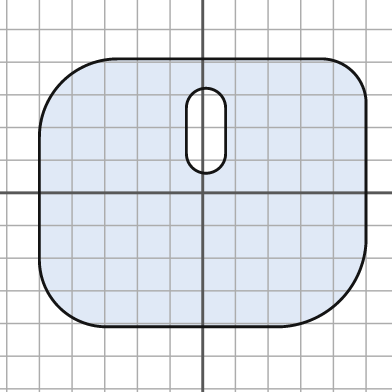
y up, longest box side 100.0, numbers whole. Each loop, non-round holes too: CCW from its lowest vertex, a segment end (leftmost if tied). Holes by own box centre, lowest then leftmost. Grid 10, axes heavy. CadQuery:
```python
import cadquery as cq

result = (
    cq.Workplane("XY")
    .moveTo(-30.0, -41.0)
    .lineTo(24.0, -41.0)
    .threePointArc((42.0, -33.0), (50.0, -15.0))
    .lineTo(50.0, 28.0)
    .threePointArc((46.0, 37.0), (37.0, 41.0))
    .lineTo(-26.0, 41.0)
    .threePointArc((-43.0, 34.0), (-50.0, 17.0))
    .lineTo(-50.0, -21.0)
    .threePointArc((-44.0, -35.0), (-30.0, -41.0))
    .close()
    .moveTo(-5.0, 12.0)
    .threePointArc((1.0, 6.0), (7.0, 12.0))
    .lineTo(7.0, 26.0)
    .threePointArc((1.0, 32.0), (-5.0, 26.0))
    .close()
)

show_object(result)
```